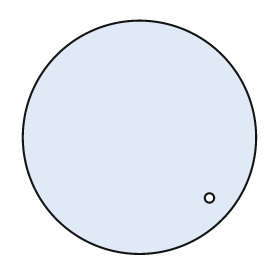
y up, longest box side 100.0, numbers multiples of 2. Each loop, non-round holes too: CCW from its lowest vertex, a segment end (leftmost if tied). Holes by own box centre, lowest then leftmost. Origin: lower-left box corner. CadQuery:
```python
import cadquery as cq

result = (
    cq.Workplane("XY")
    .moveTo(50.0, 50.0)
    .circle(50.0)
    .moveTo(80.0, 24.0)
    .circle(2.0)
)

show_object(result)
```